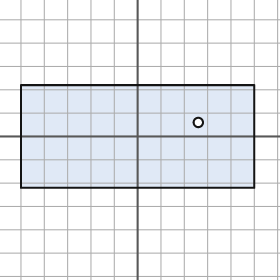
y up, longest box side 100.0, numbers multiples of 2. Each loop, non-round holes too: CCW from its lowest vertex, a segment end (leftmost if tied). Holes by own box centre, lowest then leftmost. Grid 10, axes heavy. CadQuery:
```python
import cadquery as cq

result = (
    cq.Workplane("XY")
    .moveTo(-50.0, -22.0)
    .lineTo(50.0, -22.0)
    .lineTo(50.0, 22.0)
    .lineTo(-50.0, 22.0)
    .close()
    .moveTo(26.0, 6.0)
    .circle(2.0)
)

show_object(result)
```